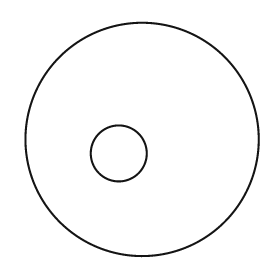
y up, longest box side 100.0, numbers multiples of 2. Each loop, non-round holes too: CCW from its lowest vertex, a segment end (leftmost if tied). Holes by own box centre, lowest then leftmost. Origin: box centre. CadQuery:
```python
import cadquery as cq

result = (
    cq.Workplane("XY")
    .moveTo(0.0, 0.0)
    .circle(50.0)
    .moveTo(-10.0, -6.0)
    .circle(12.0)
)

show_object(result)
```